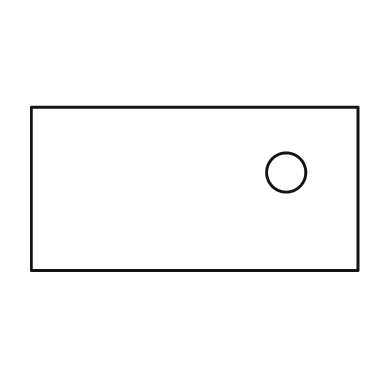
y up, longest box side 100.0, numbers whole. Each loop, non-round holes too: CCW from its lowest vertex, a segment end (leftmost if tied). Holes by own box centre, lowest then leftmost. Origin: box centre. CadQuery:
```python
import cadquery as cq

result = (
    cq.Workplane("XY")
    .moveTo(-50.0, -25.0)
    .lineTo(50.0, -25.0)
    .lineTo(50.0, 25.0)
    .lineTo(-50.0, 25.0)
    .close()
    .moveTo(28.0, 5.0)
    .circle(6.0)
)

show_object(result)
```